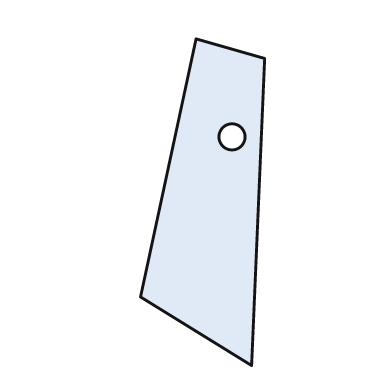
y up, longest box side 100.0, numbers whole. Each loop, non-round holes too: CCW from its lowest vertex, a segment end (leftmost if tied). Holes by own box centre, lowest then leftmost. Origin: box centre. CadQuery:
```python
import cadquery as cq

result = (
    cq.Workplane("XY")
    .moveTo(15.0, -50.0)
    .lineTo(19.0, 44.0)
    .lineTo(-2.0, 50.0)
    .lineTo(-19.0, -29.0)
    .close()
    .moveTo(9.0, 20.0)
    .circle(4.0)
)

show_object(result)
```